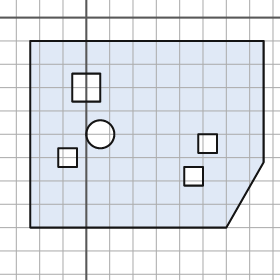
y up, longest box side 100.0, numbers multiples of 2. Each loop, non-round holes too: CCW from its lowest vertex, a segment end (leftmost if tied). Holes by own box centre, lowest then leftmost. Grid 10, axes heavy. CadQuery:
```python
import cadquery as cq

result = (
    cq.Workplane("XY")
    .moveTo(-24.0, -90.0)
    .lineTo(60.0, -90.0)
    .lineTo(76.0, -62.0)
    .lineTo(76.0, -10.0)
    .lineTo(-24.0, -10.0)
    .close()
    .moveTo(42.0, -72.0)
    .lineTo(50.0, -72.0)
    .lineTo(50.0, -64.0)
    .lineTo(42.0, -64.0)
    .close()
    .moveTo(-12.0, -64.0)
    .lineTo(-4.0, -64.0)
    .lineTo(-4.0, -56.0)
    .lineTo(-12.0, -56.0)
    .close()
    .moveTo(48.0, -58.0)
    .lineTo(56.0, -58.0)
    .lineTo(56.0, -50.0)
    .lineTo(48.0, -50.0)
    .close()
    .moveTo(6.0, -50.0)
    .circle(6.0)
    .moveTo(-6.0, -36.0)
    .lineTo(6.0, -36.0)
    .lineTo(6.0, -24.0)
    .lineTo(-6.0, -24.0)
    .close()
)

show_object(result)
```